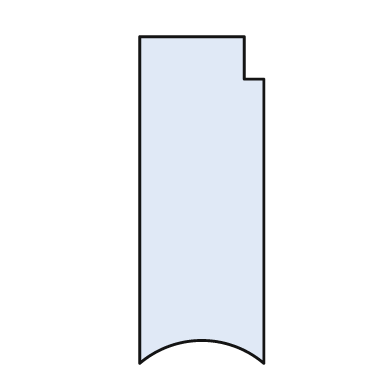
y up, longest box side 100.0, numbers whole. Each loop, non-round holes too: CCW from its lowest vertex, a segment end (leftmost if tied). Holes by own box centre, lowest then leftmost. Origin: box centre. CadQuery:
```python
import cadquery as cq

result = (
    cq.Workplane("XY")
    .moveTo(-19.0, -50.0)
    .threePointArc((0.0, -43.0), (19.0, -50.0))
    .lineTo(19.0, 37.0)
    .lineTo(13.0, 37.0)
    .lineTo(13.0, 50.0)
    .lineTo(-19.0, 50.0)
    .close()
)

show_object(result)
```